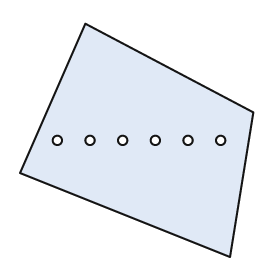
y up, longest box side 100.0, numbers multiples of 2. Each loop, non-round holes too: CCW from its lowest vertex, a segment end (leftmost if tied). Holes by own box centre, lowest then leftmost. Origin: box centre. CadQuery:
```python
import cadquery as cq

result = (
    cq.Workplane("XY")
    .moveTo(40.0, -50.0)
    .lineTo(50.0, 12.0)
    .lineTo(-22.0, 50.0)
    .lineTo(-50.0, -14.0)
    .close()
    .moveTo(-34.0, 0.0)
    .circle(2.0)
    .moveTo(-20.0, 0.0)
    .circle(2.0)
    .moveTo(-6.0, 0.0)
    .circle(2.0)
    .moveTo(8.0, 0.0)
    .circle(2.0)
    .moveTo(22.0, 0.0)
    .circle(2.0)
    .moveTo(36.0, 0.0)
    .circle(2.0)
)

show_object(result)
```